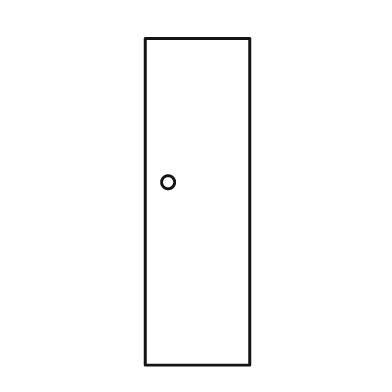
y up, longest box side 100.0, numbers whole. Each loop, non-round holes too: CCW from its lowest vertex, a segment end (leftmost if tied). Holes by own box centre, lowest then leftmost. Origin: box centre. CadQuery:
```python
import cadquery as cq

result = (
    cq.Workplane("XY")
    .moveTo(-16.0, -50.0)
    .lineTo(16.0, -50.0)
    .lineTo(16.0, 50.0)
    .lineTo(-16.0, 50.0)
    .close()
    .moveTo(-9.0, 6.0)
    .circle(2.0)
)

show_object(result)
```